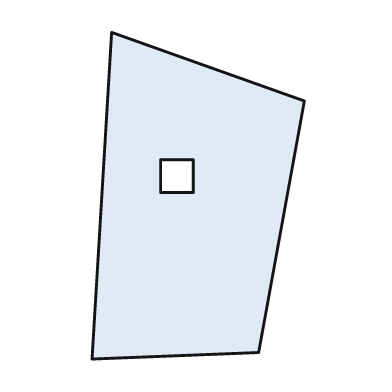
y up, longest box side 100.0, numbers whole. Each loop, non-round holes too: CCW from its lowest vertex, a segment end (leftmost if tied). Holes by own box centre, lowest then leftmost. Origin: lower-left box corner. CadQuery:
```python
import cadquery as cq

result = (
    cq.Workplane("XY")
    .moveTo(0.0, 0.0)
    .lineTo(51.0, 2.0)
    .lineTo(65.0, 79.0)
    .lineTo(6.0, 100.0)
    .close()
    .moveTo(21.0, 51.0)
    .lineTo(31.0, 51.0)
    .lineTo(31.0, 61.0)
    .lineTo(21.0, 61.0)
    .close()
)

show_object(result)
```